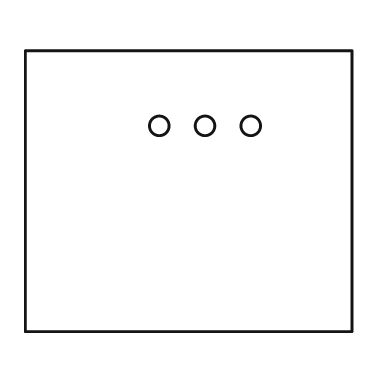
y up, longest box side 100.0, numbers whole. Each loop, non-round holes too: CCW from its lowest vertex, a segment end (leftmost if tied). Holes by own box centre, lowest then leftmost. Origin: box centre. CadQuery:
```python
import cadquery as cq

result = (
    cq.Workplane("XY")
    .moveTo(-50.0, -43.0)
    .lineTo(50.0, -43.0)
    .lineTo(50.0, 43.0)
    .lineTo(-50.0, 43.0)
    .close()
    .moveTo(-9.0, 20.0)
    .circle(3.0)
    .moveTo(5.0, 20.0)
    .circle(3.0)
    .moveTo(19.0, 20.0)
    .circle(3.0)
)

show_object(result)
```